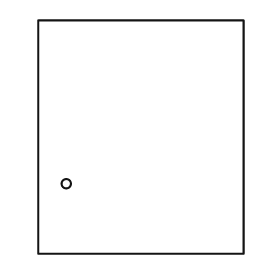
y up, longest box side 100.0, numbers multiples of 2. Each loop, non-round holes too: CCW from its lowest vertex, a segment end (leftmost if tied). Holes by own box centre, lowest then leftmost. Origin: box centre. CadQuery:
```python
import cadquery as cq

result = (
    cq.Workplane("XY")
    .moveTo(-44.0, -50.0)
    .lineTo(44.0, -50.0)
    .lineTo(44.0, 50.0)
    .lineTo(-44.0, 50.0)
    .close()
    .moveTo(-32.0, -20.0)
    .circle(2.0)
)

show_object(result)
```